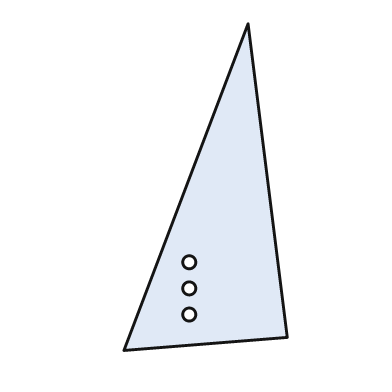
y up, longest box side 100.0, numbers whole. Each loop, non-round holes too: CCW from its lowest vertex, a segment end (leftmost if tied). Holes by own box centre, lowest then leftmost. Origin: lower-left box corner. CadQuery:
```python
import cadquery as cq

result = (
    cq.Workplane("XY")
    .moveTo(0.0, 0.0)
    .lineTo(50.0, 4.0)
    .lineTo(38.0, 100.0)
    .close()
    .moveTo(20.0, 11.0)
    .circle(2.0)
    .moveTo(20.0, 19.0)
    .circle(2.0)
    .moveTo(20.0, 27.0)
    .circle(2.0)
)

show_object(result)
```